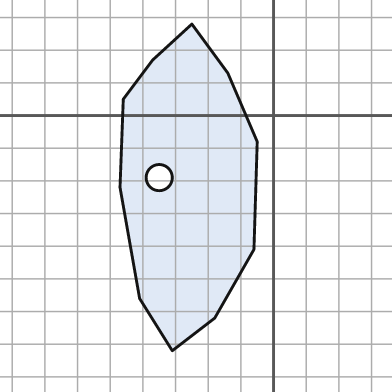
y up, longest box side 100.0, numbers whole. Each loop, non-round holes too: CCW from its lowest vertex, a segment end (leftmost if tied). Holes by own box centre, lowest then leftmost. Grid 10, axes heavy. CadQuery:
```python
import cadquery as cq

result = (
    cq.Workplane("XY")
    .moveTo(-31.0, -72.0)
    .lineTo(-18.0, -62.0)
    .lineTo(-6.0, -41.0)
    .lineTo(-5.0, -8.0)
    .lineTo(-14.0, 13.0)
    .lineTo(-25.0, 28.0)
    .lineTo(-37.0, 17.0)
    .lineTo(-46.0, 5.0)
    .lineTo(-47.0, -22.0)
    .lineTo(-41.0, -56.0)
    .close()
    .moveTo(-35.0, -19.0)
    .circle(4.0)
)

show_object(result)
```